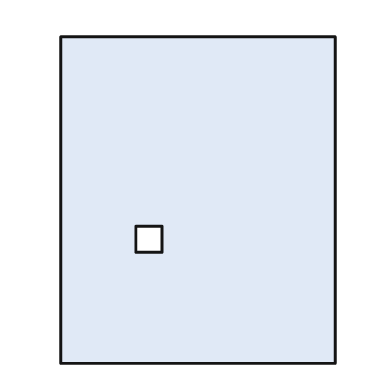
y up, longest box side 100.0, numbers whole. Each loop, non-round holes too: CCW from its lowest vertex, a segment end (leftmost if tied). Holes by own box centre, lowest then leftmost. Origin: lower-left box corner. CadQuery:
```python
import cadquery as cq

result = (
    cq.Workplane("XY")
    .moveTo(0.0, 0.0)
    .lineTo(84.0, 0.0)
    .lineTo(84.0, 100.0)
    .lineTo(0.0, 100.0)
    .close()
    .moveTo(23.0, 34.0)
    .lineTo(31.0, 34.0)
    .lineTo(31.0, 42.0)
    .lineTo(23.0, 42.0)
    .close()
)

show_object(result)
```